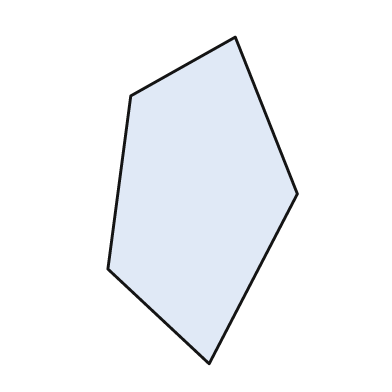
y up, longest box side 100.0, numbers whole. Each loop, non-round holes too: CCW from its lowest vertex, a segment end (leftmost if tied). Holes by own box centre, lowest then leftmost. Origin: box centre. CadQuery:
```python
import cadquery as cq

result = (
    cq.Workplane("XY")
    .moveTo(2.0, -50.0)
    .lineTo(29.0, 2.0)
    .lineTo(10.0, 50.0)
    .lineTo(-22.0, 32.0)
    .lineTo(-29.0, -21.0)
    .close()
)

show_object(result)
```